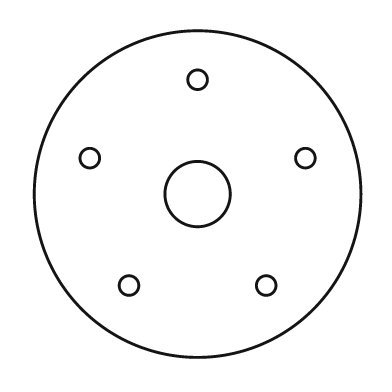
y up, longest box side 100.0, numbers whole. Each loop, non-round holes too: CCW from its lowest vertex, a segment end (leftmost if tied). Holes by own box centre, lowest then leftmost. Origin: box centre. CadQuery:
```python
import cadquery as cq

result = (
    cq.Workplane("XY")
    .moveTo(0.0, 0.0)
    .circle(50.0)
    .moveTo(-21.0, -28.0)
    .circle(3.0)
    .moveTo(21.0, -28.0)
    .circle(3.0)
    .moveTo(0.0, 0.0)
    .circle(10.0)
    .moveTo(-33.0, 11.0)
    .circle(3.0)
    .moveTo(33.0, 11.0)
    .circle(3.0)
    .moveTo(0.0, 35.0)
    .circle(3.0)
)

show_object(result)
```